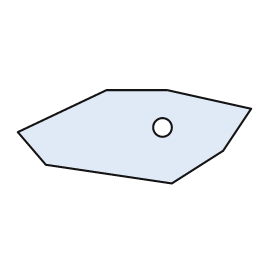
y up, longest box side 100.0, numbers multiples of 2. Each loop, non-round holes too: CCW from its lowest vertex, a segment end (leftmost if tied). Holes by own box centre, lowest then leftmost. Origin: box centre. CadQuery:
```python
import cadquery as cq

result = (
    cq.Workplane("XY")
    .moveTo(16.0, -20.0)
    .lineTo(38.0, -6.0)
    .lineTo(50.0, 12.0)
    .lineTo(14.0, 20.0)
    .lineTo(-12.0, 20.0)
    .lineTo(-50.0, 2.0)
    .lineTo(-38.0, -12.0)
    .close()
    .moveTo(12.0, 4.0)
    .circle(4.0)
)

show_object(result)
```